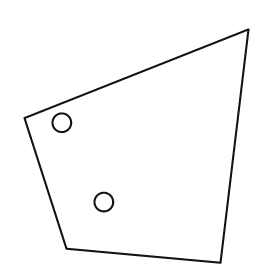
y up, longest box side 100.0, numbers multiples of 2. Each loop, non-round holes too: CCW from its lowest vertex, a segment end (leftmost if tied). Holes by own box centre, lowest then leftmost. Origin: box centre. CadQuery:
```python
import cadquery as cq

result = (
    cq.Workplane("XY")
    .moveTo(36.0, -50.0)
    .lineTo(48.0, 50.0)
    .lineTo(-48.0, 12.0)
    .lineTo(-30.0, -44.0)
    .close()
    .moveTo(-14.0, -24.0)
    .circle(4.0)
    .moveTo(-32.0, 10.0)
    .circle(4.0)
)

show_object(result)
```